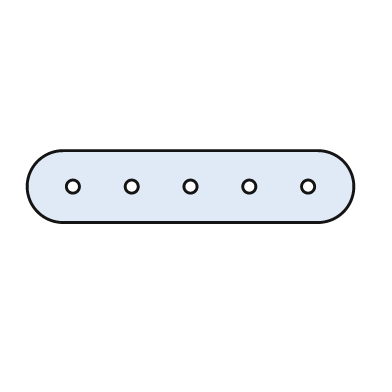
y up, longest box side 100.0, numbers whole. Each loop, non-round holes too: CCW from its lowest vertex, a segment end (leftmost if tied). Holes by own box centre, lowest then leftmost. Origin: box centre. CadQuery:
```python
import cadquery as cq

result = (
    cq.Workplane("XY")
    .moveTo(-39.0, -11.0)
    .lineTo(39.0, -11.0)
    .threePointArc((50.0, 0.0), (39.0, 11.0))
    .lineTo(-39.0, 11.0)
    .threePointArc((-50.0, 0.0), (-39.0, -11.0))
    .close()
    .moveTo(-36.0, 0.0)
    .circle(2.0)
    .moveTo(-18.0, 0.0)
    .circle(2.0)
    .moveTo(0.0, 0.0)
    .circle(2.0)
    .moveTo(18.0, 0.0)
    .circle(2.0)
    .moveTo(36.0, 0.0)
    .circle(2.0)
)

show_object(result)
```